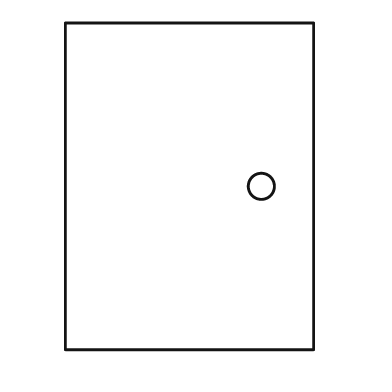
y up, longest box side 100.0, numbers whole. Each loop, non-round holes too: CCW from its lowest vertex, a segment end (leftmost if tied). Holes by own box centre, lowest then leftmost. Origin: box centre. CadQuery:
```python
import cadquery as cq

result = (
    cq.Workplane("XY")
    .moveTo(-38.0, -50.0)
    .lineTo(38.0, -50.0)
    .lineTo(38.0, 50.0)
    .lineTo(-38.0, 50.0)
    .close()
    .moveTo(22.0, 0.0)
    .circle(4.0)
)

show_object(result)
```